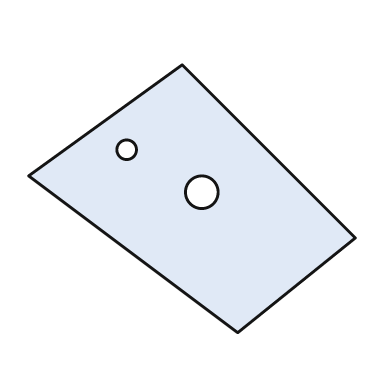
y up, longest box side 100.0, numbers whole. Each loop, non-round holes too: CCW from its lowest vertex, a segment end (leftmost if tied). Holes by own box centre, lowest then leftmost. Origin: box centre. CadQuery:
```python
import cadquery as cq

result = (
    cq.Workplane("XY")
    .moveTo(14.0, -41.0)
    .lineTo(50.0, -12.0)
    .lineTo(-3.0, 41.0)
    .lineTo(-50.0, 7.0)
    .close()
    .moveTo(3.0, 2.0)
    .circle(5.0)
    .moveTo(-20.0, 15.0)
    .circle(3.0)
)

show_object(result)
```